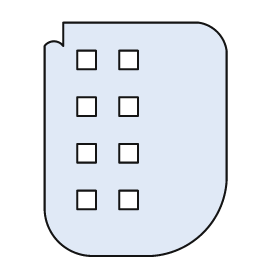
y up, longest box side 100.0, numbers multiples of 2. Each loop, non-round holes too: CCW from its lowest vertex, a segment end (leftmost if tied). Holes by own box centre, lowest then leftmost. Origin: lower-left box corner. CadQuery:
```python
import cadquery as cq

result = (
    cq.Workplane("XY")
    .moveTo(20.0, 0.0)
    .lineTo(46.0, 0.0)
    .threePointArc((68.0, 10.0), (78.0, 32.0))
    .lineTo(78.0, 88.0)
    .threePointArc((74.0, 96.0), (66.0, 100.0))
    .lineTo(8.0, 100.0)
    .lineTo(8.0, 90.0)
    .threePointArc((4.0, 92.0), (0.0, 90.0))
    .lineTo(0.0, 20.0)
    .threePointArc((6.0, 6.0), (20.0, 0.0))
    .close()
    .moveTo(14.0, 20.0)
    .lineTo(22.0, 20.0)
    .lineTo(22.0, 28.0)
    .lineTo(14.0, 28.0)
    .close()
    .moveTo(32.0, 20.0)
    .lineTo(40.0, 20.0)
    .lineTo(40.0, 28.0)
    .lineTo(32.0, 28.0)
    .close()
    .moveTo(14.0, 40.0)
    .lineTo(22.0, 40.0)
    .lineTo(22.0, 48.0)
    .lineTo(14.0, 48.0)
    .close()
    .moveTo(32.0, 40.0)
    .lineTo(40.0, 40.0)
    .lineTo(40.0, 48.0)
    .lineTo(32.0, 48.0)
    .close()
    .moveTo(14.0, 60.0)
    .lineTo(22.0, 60.0)
    .lineTo(22.0, 68.0)
    .lineTo(14.0, 68.0)
    .close()
    .moveTo(32.0, 60.0)
    .lineTo(40.0, 60.0)
    .lineTo(40.0, 68.0)
    .lineTo(32.0, 68.0)
    .close()
    .moveTo(14.0, 80.0)
    .lineTo(22.0, 80.0)
    .lineTo(22.0, 88.0)
    .lineTo(14.0, 88.0)
    .close()
    .moveTo(32.0, 80.0)
    .lineTo(40.0, 80.0)
    .lineTo(40.0, 88.0)
    .lineTo(32.0, 88.0)
    .close()
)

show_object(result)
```